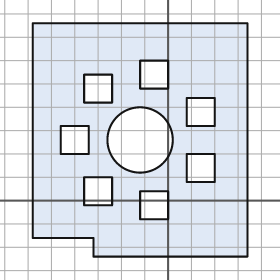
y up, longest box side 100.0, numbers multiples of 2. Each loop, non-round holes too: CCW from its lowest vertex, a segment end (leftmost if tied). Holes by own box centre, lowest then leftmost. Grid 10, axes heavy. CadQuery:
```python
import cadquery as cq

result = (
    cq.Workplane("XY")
    .moveTo(-32.0, -24.0)
    .lineTo(34.0, -24.0)
    .lineTo(34.0, 76.0)
    .lineTo(-58.0, 76.0)
    .lineTo(-58.0, -16.0)
    .lineTo(-32.0, -16.0)
    .close()
    .moveTo(-12.0, -8.0)
    .lineTo(0.0, -8.0)
    .lineTo(0.0, 4.0)
    .lineTo(-12.0, 4.0)
    .close()
    .moveTo(-36.0, -2.0)
    .lineTo(-24.0, -2.0)
    .lineTo(-24.0, 10.0)
    .lineTo(-36.0, 10.0)
    .close()
    .moveTo(8.0, 8.0)
    .lineTo(20.0, 8.0)
    .lineTo(20.0, 20.0)
    .lineTo(8.0, 20.0)
    .close()
    .moveTo(-46.0, 20.0)
    .lineTo(-34.0, 20.0)
    .lineTo(-34.0, 32.0)
    .lineTo(-46.0, 32.0)
    .close()
    .moveTo(-12.0, 26.0)
    .circle(14.0)
    .moveTo(8.0, 32.0)
    .lineTo(20.0, 32.0)
    .lineTo(20.0, 44.0)
    .lineTo(8.0, 44.0)
    .close()
    .moveTo(-36.0, 42.0)
    .lineTo(-24.0, 42.0)
    .lineTo(-24.0, 54.0)
    .lineTo(-36.0, 54.0)
    .close()
    .moveTo(-12.0, 48.0)
    .lineTo(0.0, 48.0)
    .lineTo(0.0, 60.0)
    .lineTo(-12.0, 60.0)
    .close()
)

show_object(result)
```